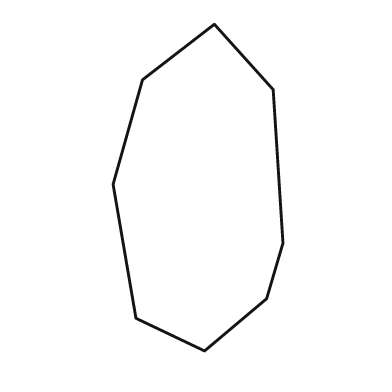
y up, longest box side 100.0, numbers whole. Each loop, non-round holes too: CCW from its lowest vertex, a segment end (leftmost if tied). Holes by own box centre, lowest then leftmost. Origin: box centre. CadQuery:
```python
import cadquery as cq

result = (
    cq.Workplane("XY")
    .moveTo(2.0, -50.0)
    .lineTo(21.0, -34.0)
    .lineTo(26.0, -17.0)
    .lineTo(23.0, 30.0)
    .lineTo(5.0, 50.0)
    .lineTo(-17.0, 33.0)
    .lineTo(-26.0, 1.0)
    .lineTo(-19.0, -40.0)
    .close()
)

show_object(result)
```